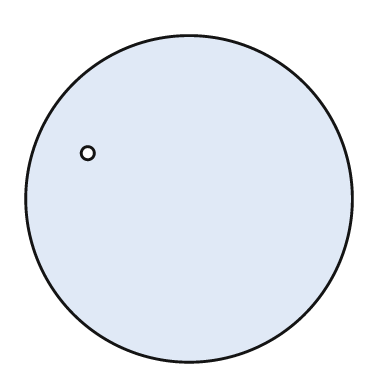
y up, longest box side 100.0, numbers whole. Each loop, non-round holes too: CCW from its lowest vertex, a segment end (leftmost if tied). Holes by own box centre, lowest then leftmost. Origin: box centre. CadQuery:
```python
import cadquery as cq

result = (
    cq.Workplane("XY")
    .moveTo(0.0, 0.0)
    .circle(50.0)
    .moveTo(-31.0, 14.0)
    .circle(2.0)
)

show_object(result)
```